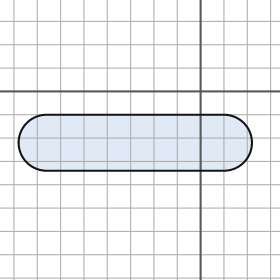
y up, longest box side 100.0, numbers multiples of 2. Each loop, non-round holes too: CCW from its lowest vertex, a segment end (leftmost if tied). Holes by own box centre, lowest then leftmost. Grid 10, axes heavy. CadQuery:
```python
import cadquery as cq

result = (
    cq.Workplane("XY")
    .moveTo(-66.0, -34.0)
    .lineTo(10.0, -34.0)
    .threePointArc((22.0, -22.0), (10.0, -10.0))
    .lineTo(-66.0, -10.0)
    .threePointArc((-78.0, -22.0), (-66.0, -34.0))
    .close()
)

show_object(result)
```